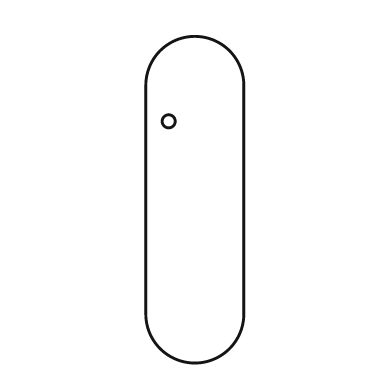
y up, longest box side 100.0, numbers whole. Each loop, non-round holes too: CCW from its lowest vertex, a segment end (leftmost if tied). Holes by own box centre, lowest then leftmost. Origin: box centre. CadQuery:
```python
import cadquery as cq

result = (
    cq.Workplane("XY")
    .moveTo(-15.0, -35.0)
    .threePointArc((0.0, -50.0), (15.0, -35.0))
    .lineTo(15.0, 35.0)
    .threePointArc((0.0, 50.0), (-15.0, 35.0))
    .close()
    .moveTo(-8.0, 24.0)
    .circle(2.0)
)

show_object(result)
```